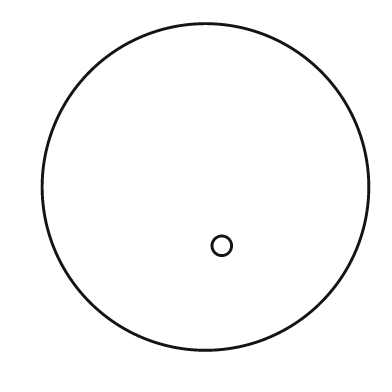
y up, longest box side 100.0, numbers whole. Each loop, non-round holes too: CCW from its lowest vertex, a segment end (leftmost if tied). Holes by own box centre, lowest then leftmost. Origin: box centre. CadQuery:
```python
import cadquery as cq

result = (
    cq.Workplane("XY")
    .moveTo(0.0, 0.0)
    .circle(50.0)
    .moveTo(5.0, -18.0)
    .circle(3.0)
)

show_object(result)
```